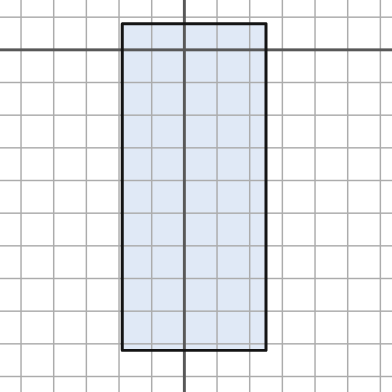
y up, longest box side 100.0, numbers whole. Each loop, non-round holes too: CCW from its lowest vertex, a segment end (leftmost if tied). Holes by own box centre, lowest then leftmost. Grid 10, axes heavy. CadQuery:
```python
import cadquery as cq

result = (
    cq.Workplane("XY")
    .moveTo(-19.0, -92.0)
    .lineTo(25.0, -92.0)
    .lineTo(25.0, 8.0)
    .lineTo(-19.0, 8.0)
    .close()
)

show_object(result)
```